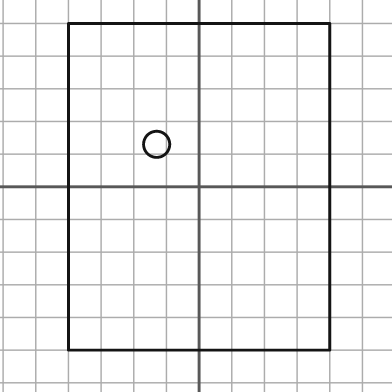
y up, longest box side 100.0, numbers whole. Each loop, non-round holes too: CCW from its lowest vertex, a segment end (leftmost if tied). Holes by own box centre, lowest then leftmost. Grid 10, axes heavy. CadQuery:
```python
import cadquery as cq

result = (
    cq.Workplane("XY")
    .moveTo(-40.0, -50.0)
    .lineTo(40.0, -50.0)
    .lineTo(40.0, 50.0)
    .lineTo(-40.0, 50.0)
    .close()
    .moveTo(-13.0, 13.0)
    .circle(4.0)
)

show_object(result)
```